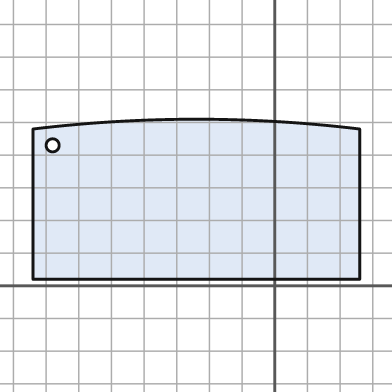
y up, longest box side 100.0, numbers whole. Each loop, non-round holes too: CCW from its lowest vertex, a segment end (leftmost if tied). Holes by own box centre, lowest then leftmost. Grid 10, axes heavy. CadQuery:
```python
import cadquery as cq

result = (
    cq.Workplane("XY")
    .moveTo(-74.0, 2.0)
    .lineTo(26.0, 2.0)
    .lineTo(26.0, 48.0)
    .threePointArc((-24.0, 51.0), (-74.0, 48.0))
    .close()
    .moveTo(-68.0, 43.0)
    .circle(2.0)
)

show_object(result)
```